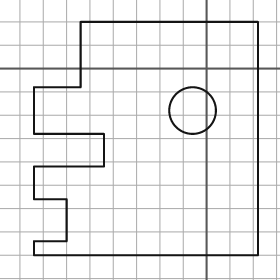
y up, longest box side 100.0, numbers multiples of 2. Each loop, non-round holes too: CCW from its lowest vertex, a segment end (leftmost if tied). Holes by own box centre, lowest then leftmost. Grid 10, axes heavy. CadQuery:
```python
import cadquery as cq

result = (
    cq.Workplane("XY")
    .moveTo(-74.0, -80.0)
    .lineTo(22.0, -80.0)
    .lineTo(22.0, 20.0)
    .lineTo(-54.0, 20.0)
    .lineTo(-54.0, -8.0)
    .lineTo(-74.0, -8.0)
    .lineTo(-74.0, -28.0)
    .lineTo(-44.0, -28.0)
    .lineTo(-44.0, -42.0)
    .lineTo(-74.0, -42.0)
    .lineTo(-74.0, -56.0)
    .lineTo(-60.0, -56.0)
    .lineTo(-60.0, -74.0)
    .lineTo(-74.0, -74.0)
    .close()
    .moveTo(-6.0, -18.0)
    .circle(10.0)
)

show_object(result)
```